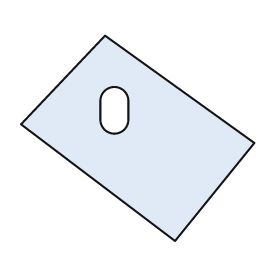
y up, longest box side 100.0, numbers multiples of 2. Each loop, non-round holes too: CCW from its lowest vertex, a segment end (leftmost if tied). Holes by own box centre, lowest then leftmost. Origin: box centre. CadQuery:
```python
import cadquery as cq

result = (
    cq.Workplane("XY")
    .moveTo(16.0, -44.0)
    .lineTo(50.0, -2.0)
    .lineTo(-14.0, 44.0)
    .lineTo(-50.0, 6.0)
    .close()
    .moveTo(-16.0, 8.0)
    .threePointArc((-10.0, 2.0), (-4.0, 8.0))
    .lineTo(-4.0, 16.0)
    .threePointArc((-10.0, 22.0), (-16.0, 16.0))
    .close()
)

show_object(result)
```